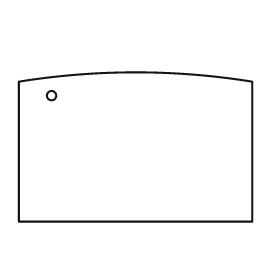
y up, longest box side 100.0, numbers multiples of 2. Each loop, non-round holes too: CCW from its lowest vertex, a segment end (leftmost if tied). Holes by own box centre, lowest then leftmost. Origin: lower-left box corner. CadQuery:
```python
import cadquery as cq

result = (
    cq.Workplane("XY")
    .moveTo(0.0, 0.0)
    .lineTo(100.0, 0.0)
    .lineTo(100.0, 60.0)
    .threePointArc((50.0, 64.0), (0.0, 60.0))
    .close()
    .moveTo(14.0, 54.0)
    .circle(2.0)
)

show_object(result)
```